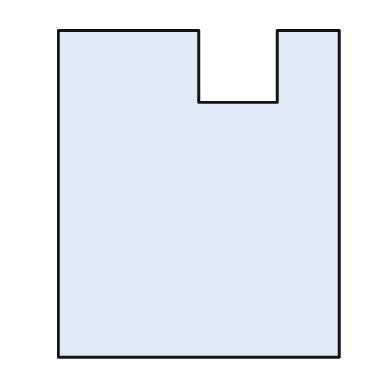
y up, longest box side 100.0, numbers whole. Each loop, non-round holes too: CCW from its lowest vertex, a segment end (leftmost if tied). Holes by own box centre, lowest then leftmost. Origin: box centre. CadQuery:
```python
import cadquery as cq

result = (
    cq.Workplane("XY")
    .moveTo(-43.0, -50.0)
    .lineTo(43.0, -50.0)
    .lineTo(43.0, 50.0)
    .lineTo(24.0, 50.0)
    .lineTo(24.0, 28.0)
    .lineTo(0.0, 28.0)
    .lineTo(0.0, 50.0)
    .lineTo(-43.0, 50.0)
    .close()
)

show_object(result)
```